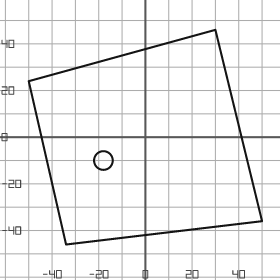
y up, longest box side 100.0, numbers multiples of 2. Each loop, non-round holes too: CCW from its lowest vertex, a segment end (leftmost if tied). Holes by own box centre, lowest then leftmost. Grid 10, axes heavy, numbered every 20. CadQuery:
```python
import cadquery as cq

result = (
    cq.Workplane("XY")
    .moveTo(-34.0, -46.0)
    .lineTo(50.0, -36.0)
    .lineTo(30.0, 46.0)
    .lineTo(-50.0, 24.0)
    .close()
    .moveTo(-18.0, -10.0)
    .circle(4.0)
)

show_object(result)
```